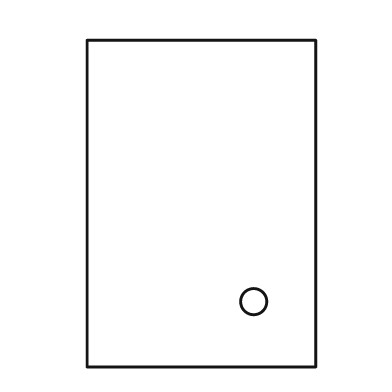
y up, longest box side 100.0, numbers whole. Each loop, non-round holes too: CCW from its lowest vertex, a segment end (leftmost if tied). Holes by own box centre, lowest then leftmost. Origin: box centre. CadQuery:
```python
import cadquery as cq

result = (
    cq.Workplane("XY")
    .moveTo(-35.0, -50.0)
    .lineTo(35.0, -50.0)
    .lineTo(35.0, 50.0)
    .lineTo(-35.0, 50.0)
    .close()
    .moveTo(16.0, -30.0)
    .circle(4.0)
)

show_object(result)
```